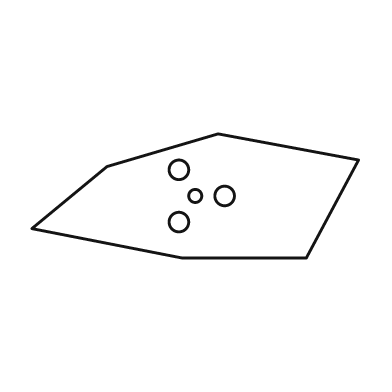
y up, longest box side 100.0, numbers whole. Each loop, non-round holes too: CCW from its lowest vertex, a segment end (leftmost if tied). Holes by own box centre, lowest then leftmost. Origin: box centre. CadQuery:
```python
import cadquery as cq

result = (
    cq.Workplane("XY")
    .moveTo(-4.0, -19.0)
    .lineTo(34.0, -19.0)
    .lineTo(50.0, 11.0)
    .lineTo(7.0, 19.0)
    .lineTo(-27.0, 9.0)
    .lineTo(-50.0, -10.0)
    .close()
    .moveTo(-5.0, -8.0)
    .circle(3.0)
    .moveTo(0.0, 0.0)
    .circle(2.0)
    .moveTo(9.0, 0.0)
    .circle(3.0)
    .moveTo(-5.0, 8.0)
    .circle(3.0)
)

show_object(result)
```